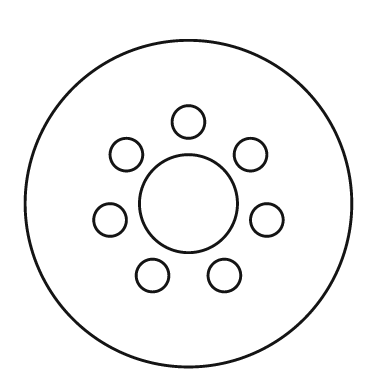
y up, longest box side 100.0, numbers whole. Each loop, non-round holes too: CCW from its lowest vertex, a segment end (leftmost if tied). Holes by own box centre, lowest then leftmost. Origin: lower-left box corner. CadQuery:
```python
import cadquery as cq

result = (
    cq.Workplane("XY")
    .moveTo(50.0, 50.0)
    .circle(50.0)
    .moveTo(39.0, 28.0)
    .circle(5.0)
    .moveTo(61.0, 28.0)
    .circle(5.0)
    .moveTo(26.0, 45.0)
    .circle(5.0)
    .moveTo(74.0, 45.0)
    .circle(5.0)
    .moveTo(50.0, 50.0)
    .circle(15.0)
    .moveTo(31.0, 65.0)
    .circle(5.0)
    .moveTo(69.0, 65.0)
    .circle(5.0)
    .moveTo(50.0, 75.0)
    .circle(5.0)
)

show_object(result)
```